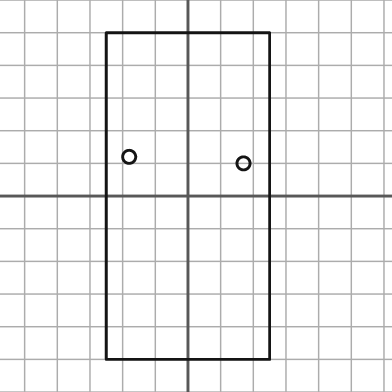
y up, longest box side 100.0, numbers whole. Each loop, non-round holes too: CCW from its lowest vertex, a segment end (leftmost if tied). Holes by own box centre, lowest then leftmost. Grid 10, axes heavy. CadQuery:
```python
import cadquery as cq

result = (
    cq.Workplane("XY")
    .moveTo(-25.0, -50.0)
    .lineTo(25.0, -50.0)
    .lineTo(25.0, 50.0)
    .lineTo(-25.0, 50.0)
    .close()
    .moveTo(17.0, 10.0)
    .circle(2.0)
    .moveTo(-18.0, 12.0)
    .circle(2.0)
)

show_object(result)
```